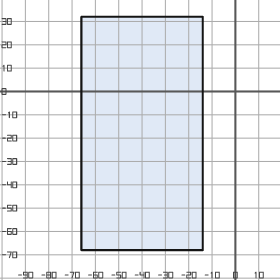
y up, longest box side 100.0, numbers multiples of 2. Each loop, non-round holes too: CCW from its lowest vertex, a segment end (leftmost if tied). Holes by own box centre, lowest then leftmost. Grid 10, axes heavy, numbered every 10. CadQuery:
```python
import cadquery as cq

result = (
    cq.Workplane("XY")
    .moveTo(-66.0, -68.0)
    .lineTo(-14.0, -68.0)
    .lineTo(-14.0, 32.0)
    .lineTo(-66.0, 32.0)
    .close()
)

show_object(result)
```